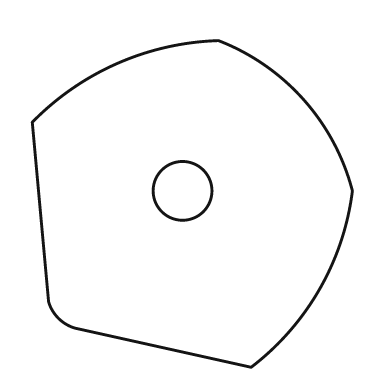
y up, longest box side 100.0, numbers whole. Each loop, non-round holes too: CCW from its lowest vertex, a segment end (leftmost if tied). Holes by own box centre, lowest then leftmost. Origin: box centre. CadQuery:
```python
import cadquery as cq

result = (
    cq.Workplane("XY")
    .moveTo(18.0, -50.0)
    .threePointArc((39.0, -26.0), (49.0, 4.0))
    .threePointArc((34.0, 32.0), (8.0, 50.0))
    .threePointArc((-23.0, 43.0), (-49.0, 25.0))
    .lineTo(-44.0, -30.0)
    .threePointArc((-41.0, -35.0), (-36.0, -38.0))
    .close()
    .moveTo(-3.0, 4.0)
    .circle(9.0)
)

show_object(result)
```